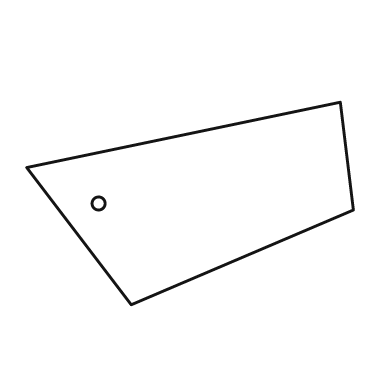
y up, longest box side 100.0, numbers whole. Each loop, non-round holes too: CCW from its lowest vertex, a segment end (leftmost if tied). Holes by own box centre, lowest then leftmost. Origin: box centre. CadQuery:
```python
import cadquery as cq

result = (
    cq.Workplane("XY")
    .moveTo(-18.0, -31.0)
    .lineTo(50.0, -2.0)
    .lineTo(46.0, 31.0)
    .lineTo(-50.0, 11.0)
    .close()
    .moveTo(-28.0, 0.0)
    .circle(2.0)
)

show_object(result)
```